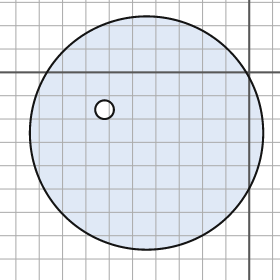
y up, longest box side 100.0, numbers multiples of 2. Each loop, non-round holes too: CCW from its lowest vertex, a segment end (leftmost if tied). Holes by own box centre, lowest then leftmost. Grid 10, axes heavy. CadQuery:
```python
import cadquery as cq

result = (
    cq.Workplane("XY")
    .moveTo(-44.0, -26.0)
    .circle(50.0)
    .moveTo(-62.0, -16.0)
    .circle(4.0)
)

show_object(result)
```